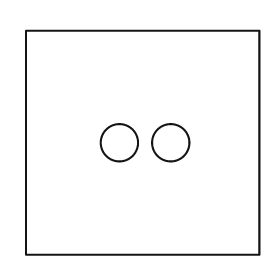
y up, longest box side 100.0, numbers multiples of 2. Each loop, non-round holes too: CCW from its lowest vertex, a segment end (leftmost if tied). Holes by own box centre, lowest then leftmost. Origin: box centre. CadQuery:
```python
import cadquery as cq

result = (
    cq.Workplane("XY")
    .moveTo(-50.0, -48.0)
    .lineTo(50.0, -48.0)
    .lineTo(50.0, 48.0)
    .lineTo(-50.0, 48.0)
    .close()
    .moveTo(-10.0, 0.0)
    .circle(8.0)
    .moveTo(12.0, 0.0)
    .circle(8.0)
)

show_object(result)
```